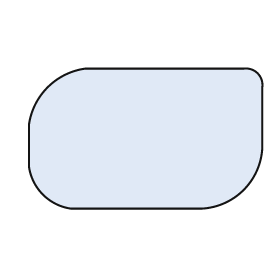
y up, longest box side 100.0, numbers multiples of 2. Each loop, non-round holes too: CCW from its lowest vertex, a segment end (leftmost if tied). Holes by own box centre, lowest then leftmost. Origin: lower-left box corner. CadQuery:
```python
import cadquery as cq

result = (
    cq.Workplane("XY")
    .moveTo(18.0, 0.0)
    .lineTo(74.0, 0.0)
    .threePointArc((92.0, 8.0), (100.0, 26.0))
    .lineTo(100.0, 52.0)
    .threePointArc((98.0, 58.0), (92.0, 60.0))
    .lineTo(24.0, 60.0)
    .threePointArc((8.0, 52.0), (0.0, 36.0))
    .lineTo(0.0, 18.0)
    .threePointArc((6.0, 6.0), (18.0, 0.0))
    .close()
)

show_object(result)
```